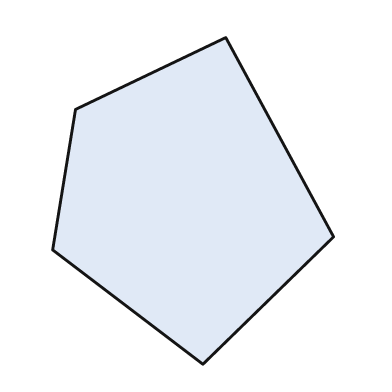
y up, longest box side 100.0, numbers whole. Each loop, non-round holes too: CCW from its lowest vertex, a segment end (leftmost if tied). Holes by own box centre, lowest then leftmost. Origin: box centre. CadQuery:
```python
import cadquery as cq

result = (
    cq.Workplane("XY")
    .moveTo(3.0, -50.0)
    .lineTo(43.0, -11.0)
    .lineTo(10.0, 50.0)
    .lineTo(-36.0, 28.0)
    .lineTo(-43.0, -15.0)
    .close()
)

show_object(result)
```